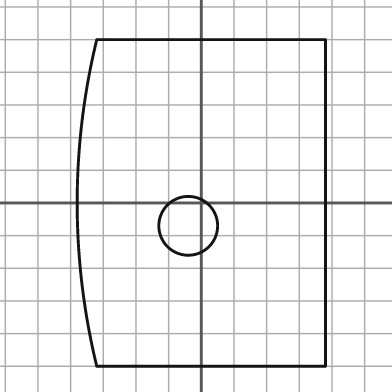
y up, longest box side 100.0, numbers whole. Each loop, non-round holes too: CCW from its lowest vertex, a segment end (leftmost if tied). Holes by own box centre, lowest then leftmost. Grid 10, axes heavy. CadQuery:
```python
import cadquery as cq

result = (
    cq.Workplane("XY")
    .moveTo(-32.0, -50.0)
    .lineTo(38.0, -50.0)
    .lineTo(38.0, 50.0)
    .lineTo(-32.0, 50.0)
    .threePointArc((-38.0, 0.0), (-32.0, -50.0))
    .close()
    .moveTo(-4.0, -7.0)
    .circle(9.0)
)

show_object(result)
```